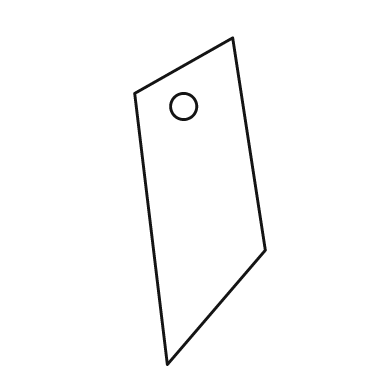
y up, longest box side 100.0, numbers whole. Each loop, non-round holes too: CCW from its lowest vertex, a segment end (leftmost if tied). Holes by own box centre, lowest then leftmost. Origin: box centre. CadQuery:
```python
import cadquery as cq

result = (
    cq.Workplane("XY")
    .moveTo(-10.0, -50.0)
    .lineTo(20.0, -15.0)
    .lineTo(10.0, 50.0)
    .lineTo(-20.0, 33.0)
    .close()
    .moveTo(-5.0, 29.0)
    .circle(4.0)
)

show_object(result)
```